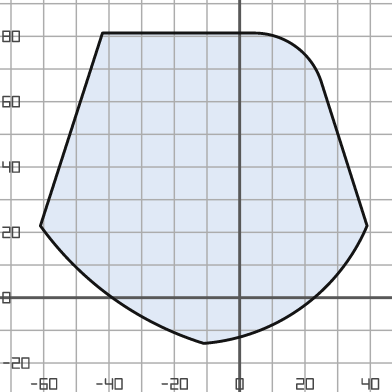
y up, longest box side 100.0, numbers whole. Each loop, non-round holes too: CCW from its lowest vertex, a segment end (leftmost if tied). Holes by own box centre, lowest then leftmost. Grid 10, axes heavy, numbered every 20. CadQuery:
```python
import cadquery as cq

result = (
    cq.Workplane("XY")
    .moveTo(-11.0, -14.0)
    .threePointArc((19.0, -3.0), (39.0, 22.0))
    .lineTo(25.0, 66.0)
    .threePointArc((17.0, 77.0), (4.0, 81.0))
    .lineTo(-42.0, 81.0)
    .lineTo(-61.0, 22.0)
    .threePointArc((-39.0, 0.0), (-11.0, -14.0))
    .close()
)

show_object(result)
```